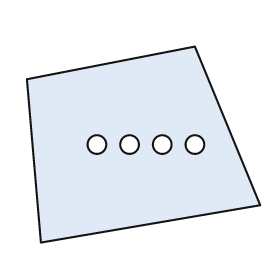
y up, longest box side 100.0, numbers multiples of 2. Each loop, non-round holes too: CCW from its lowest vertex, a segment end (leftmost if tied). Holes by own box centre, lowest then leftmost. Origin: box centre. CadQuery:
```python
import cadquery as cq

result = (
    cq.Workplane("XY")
    .moveTo(-44.0, -42.0)
    .lineTo(50.0, -26.0)
    .lineTo(22.0, 42.0)
    .lineTo(-50.0, 28.0)
    .close()
    .moveTo(-20.0, 0.0)
    .circle(4.0)
    .moveTo(-6.0, 0.0)
    .circle(4.0)
    .moveTo(8.0, 0.0)
    .circle(4.0)
    .moveTo(22.0, 0.0)
    .circle(4.0)
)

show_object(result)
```